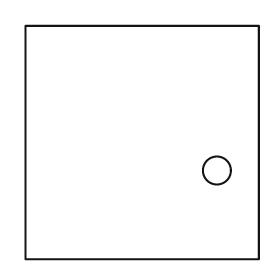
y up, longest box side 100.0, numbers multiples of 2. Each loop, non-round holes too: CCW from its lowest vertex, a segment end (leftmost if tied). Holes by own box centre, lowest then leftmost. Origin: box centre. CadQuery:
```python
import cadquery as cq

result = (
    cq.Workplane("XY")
    .moveTo(-50.0, -50.0)
    .lineTo(50.0, -50.0)
    .lineTo(50.0, 50.0)
    .lineTo(-50.0, 50.0)
    .close()
    .moveTo(32.0, -12.0)
    .circle(6.0)
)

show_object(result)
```